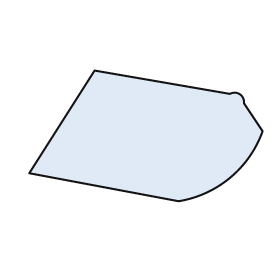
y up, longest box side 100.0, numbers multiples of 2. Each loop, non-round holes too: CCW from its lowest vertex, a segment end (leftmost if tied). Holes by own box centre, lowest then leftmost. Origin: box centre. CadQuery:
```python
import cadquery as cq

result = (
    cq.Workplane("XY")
    .moveTo(14.0, -28.0)
    .threePointArc((36.0, -18.0), (50.0, 2.0))
    .lineTo(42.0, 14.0)
    .threePointArc((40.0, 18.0), (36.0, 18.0))
    .lineTo(-22.0, 28.0)
    .lineTo(-50.0, -16.0)
    .close()
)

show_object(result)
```